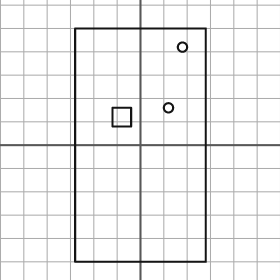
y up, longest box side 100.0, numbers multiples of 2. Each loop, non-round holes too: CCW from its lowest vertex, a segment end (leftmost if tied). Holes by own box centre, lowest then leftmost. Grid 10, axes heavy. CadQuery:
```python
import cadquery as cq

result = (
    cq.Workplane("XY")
    .moveTo(-28.0, -50.0)
    .lineTo(28.0, -50.0)
    .lineTo(28.0, 50.0)
    .lineTo(-28.0, 50.0)
    .close()
    .moveTo(-12.0, 8.0)
    .lineTo(-4.0, 8.0)
    .lineTo(-4.0, 16.0)
    .lineTo(-12.0, 16.0)
    .close()
    .moveTo(12.0, 16.0)
    .circle(2.0)
    .moveTo(18.0, 42.0)
    .circle(2.0)
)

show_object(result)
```